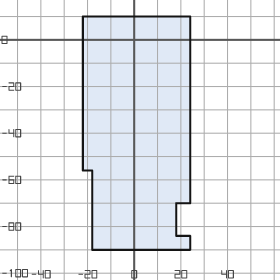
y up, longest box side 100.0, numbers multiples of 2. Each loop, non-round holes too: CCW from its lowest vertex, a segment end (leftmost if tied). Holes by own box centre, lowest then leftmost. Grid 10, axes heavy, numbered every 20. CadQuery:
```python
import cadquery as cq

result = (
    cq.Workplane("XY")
    .moveTo(-18.0, -90.0)
    .lineTo(24.0, -90.0)
    .lineTo(24.0, -84.0)
    .lineTo(18.0, -84.0)
    .lineTo(18.0, -70.0)
    .lineTo(24.0, -70.0)
    .lineTo(24.0, 10.0)
    .lineTo(-22.0, 10.0)
    .lineTo(-22.0, -56.0)
    .lineTo(-18.0, -56.0)
    .close()
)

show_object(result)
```